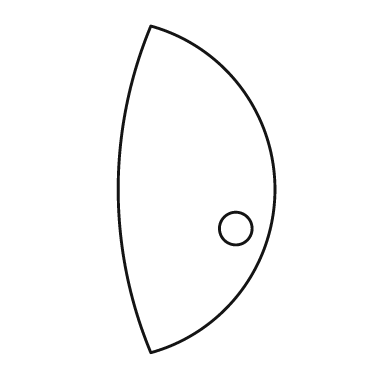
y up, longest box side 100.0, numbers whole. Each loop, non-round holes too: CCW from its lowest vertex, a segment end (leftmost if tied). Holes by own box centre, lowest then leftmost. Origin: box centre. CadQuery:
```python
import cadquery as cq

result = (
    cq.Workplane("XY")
    .moveTo(-14.0, -50.0)
    .threePointArc((24.0, 0.0), (-14.0, 50.0))
    .threePointArc((-24.0, 0.0), (-14.0, -50.0))
    .close()
    .moveTo(12.0, -12.0)
    .circle(5.0)
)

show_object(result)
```